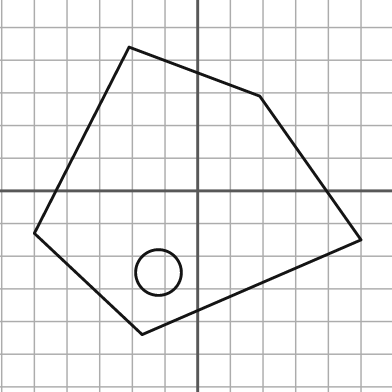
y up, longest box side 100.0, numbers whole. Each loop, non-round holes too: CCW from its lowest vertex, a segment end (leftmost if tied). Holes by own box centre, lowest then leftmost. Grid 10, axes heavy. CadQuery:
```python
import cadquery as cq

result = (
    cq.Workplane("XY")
    .moveTo(-17.0, -44.0)
    .lineTo(50.0, -15.0)
    .lineTo(19.0, 29.0)
    .lineTo(-21.0, 44.0)
    .lineTo(-50.0, -13.0)
    .close()
    .moveTo(-12.0, -25.0)
    .circle(7.0)
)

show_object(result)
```